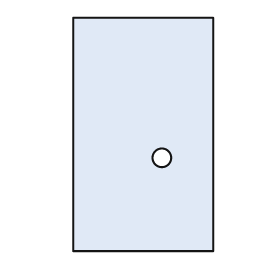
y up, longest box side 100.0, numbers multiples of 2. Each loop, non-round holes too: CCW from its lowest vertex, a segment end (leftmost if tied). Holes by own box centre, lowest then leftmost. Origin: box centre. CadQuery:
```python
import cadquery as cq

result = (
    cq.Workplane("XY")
    .moveTo(-30.0, -50.0)
    .lineTo(30.0, -50.0)
    .lineTo(30.0, 50.0)
    .lineTo(-30.0, 50.0)
    .close()
    .moveTo(8.0, -10.0)
    .circle(4.0)
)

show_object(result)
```